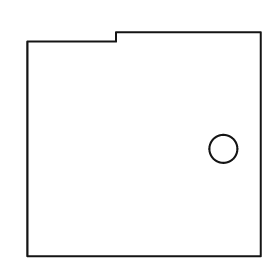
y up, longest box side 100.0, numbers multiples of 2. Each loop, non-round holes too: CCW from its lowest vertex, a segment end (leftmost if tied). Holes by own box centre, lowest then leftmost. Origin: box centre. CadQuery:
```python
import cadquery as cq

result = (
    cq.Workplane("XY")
    .moveTo(-50.0, -48.0)
    .lineTo(50.0, -48.0)
    .lineTo(50.0, 48.0)
    .lineTo(-12.0, 48.0)
    .lineTo(-12.0, 44.0)
    .lineTo(-50.0, 44.0)
    .close()
    .moveTo(34.0, -2.0)
    .circle(6.0)
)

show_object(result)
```